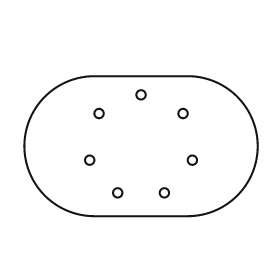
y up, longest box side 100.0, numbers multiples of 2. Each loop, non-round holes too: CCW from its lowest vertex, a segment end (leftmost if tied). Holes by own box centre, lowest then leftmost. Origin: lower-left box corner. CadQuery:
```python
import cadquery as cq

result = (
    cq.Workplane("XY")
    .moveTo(30.0, 0.0)
    .lineTo(70.0, 0.0)
    .threePointArc((100.0, 30.0), (70.0, 60.0))
    .lineTo(30.0, 60.0)
    .threePointArc((0.0, 30.0), (30.0, 0.0))
    .close()
    .moveTo(40.0, 10.0)
    .circle(2.0)
    .moveTo(60.0, 10.0)
    .circle(2.0)
    .moveTo(28.0, 24.0)
    .circle(2.0)
    .moveTo(72.0, 24.0)
    .circle(2.0)
    .moveTo(32.0, 44.0)
    .circle(2.0)
    .moveTo(68.0, 44.0)
    .circle(2.0)
    .moveTo(50.0, 52.0)
    .circle(2.0)
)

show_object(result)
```